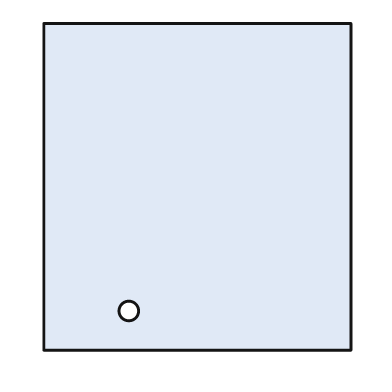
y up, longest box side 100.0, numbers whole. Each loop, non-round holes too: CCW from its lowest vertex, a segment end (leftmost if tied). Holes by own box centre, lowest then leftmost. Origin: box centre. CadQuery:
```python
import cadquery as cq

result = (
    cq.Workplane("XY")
    .moveTo(-47.0, -50.0)
    .lineTo(47.0, -50.0)
    .lineTo(47.0, 50.0)
    .lineTo(-47.0, 50.0)
    .close()
    .moveTo(-21.0, -38.0)
    .circle(3.0)
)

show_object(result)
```